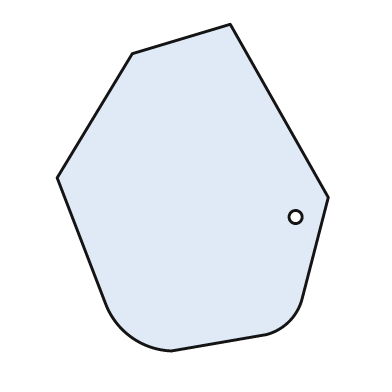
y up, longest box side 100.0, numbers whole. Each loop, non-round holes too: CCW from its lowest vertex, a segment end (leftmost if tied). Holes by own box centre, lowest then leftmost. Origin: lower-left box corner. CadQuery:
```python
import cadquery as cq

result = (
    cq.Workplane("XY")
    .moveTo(35.0, 0.0)
    .lineTo(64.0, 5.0)
    .threePointArc((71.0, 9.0), (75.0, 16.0))
    .lineTo(83.0, 47.0)
    .lineTo(53.0, 100.0)
    .lineTo(23.0, 91.0)
    .lineTo(0.0, 53.0)
    .lineTo(15.0, 14.0)
    .threePointArc((23.0, 4.0), (35.0, 0.0))
    .close()
    .moveTo(73.0, 41.0)
    .circle(2.0)
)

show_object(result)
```